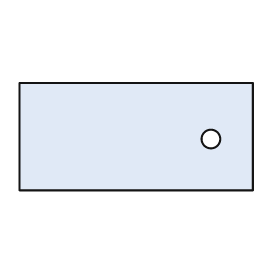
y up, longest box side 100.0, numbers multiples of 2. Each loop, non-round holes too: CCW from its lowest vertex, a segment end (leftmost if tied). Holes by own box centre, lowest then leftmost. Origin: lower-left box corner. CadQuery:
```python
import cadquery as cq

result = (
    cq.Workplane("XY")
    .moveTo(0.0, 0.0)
    .lineTo(100.0, 0.0)
    .lineTo(100.0, 46.0)
    .lineTo(0.0, 46.0)
    .close()
    .moveTo(82.0, 22.0)
    .circle(4.0)
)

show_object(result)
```